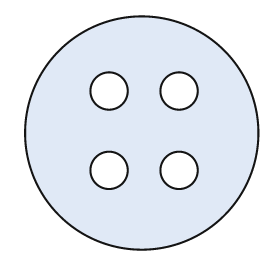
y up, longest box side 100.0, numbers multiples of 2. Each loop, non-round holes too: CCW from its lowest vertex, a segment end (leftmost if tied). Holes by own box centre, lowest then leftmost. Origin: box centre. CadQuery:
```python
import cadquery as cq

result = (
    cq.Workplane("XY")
    .moveTo(0.0, 0.0)
    .circle(50.0)
    .moveTo(-14.0, -16.0)
    .circle(8.0)
    .moveTo(16.0, -16.0)
    .circle(8.0)
    .moveTo(-14.0, 18.0)
    .circle(8.0)
    .moveTo(16.0, 18.0)
    .circle(8.0)
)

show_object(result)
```